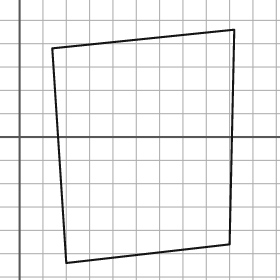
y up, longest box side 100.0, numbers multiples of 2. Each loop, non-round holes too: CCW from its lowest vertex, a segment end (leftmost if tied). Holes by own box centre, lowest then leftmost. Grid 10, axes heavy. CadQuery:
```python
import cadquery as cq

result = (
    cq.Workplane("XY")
    .moveTo(20.0, -54.0)
    .lineTo(90.0, -46.0)
    .lineTo(92.0, 46.0)
    .lineTo(14.0, 38.0)
    .close()
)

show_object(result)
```